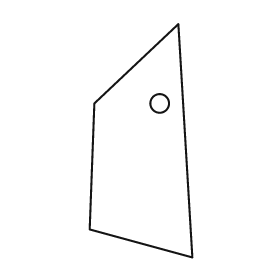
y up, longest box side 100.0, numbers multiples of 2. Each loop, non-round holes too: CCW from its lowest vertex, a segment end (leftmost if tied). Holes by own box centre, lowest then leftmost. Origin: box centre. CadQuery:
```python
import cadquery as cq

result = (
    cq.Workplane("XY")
    .moveTo(22.0, -50.0)
    .lineTo(16.0, 50.0)
    .lineTo(-20.0, 16.0)
    .lineTo(-22.0, -38.0)
    .close()
    .moveTo(8.0, 16.0)
    .circle(4.0)
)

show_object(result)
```